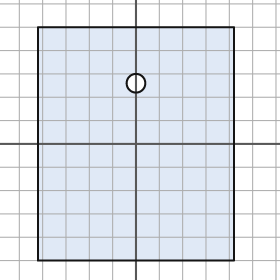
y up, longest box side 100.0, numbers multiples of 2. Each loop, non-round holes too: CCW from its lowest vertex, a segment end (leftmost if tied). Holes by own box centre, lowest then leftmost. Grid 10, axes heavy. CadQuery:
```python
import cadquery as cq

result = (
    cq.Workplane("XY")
    .moveTo(-42.0, -50.0)
    .lineTo(42.0, -50.0)
    .lineTo(42.0, 50.0)
    .lineTo(-42.0, 50.0)
    .close()
    .moveTo(0.0, 26.0)
    .circle(4.0)
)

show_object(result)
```